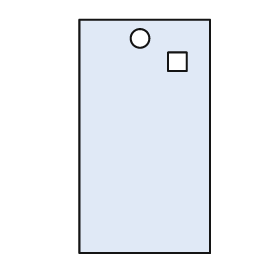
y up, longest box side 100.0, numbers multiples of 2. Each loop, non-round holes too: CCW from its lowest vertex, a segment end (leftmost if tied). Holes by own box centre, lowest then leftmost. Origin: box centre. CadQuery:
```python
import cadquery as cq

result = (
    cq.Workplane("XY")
    .moveTo(-28.0, -50.0)
    .lineTo(28.0, -50.0)
    .lineTo(28.0, 50.0)
    .lineTo(-28.0, 50.0)
    .close()
    .moveTo(10.0, 28.0)
    .lineTo(18.0, 28.0)
    .lineTo(18.0, 36.0)
    .lineTo(10.0, 36.0)
    .close()
    .moveTo(-2.0, 42.0)
    .circle(4.0)
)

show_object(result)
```